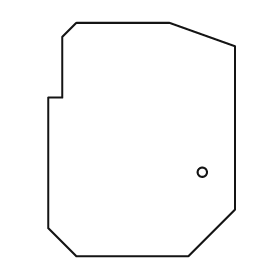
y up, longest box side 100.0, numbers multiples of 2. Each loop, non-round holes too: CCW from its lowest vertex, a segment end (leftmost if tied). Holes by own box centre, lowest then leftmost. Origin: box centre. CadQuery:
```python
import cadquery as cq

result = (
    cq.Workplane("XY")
    .moveTo(-28.0, -50.0)
    .lineTo(20.0, -50.0)
    .lineTo(40.0, -30.0)
    .lineTo(40.0, 40.0)
    .lineTo(12.0, 50.0)
    .lineTo(-28.0, 50.0)
    .lineTo(-34.0, 44.0)
    .lineTo(-34.0, 18.0)
    .lineTo(-40.0, 18.0)
    .lineTo(-40.0, -38.0)
    .close()
    .moveTo(26.0, -14.0)
    .circle(2.0)
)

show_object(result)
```